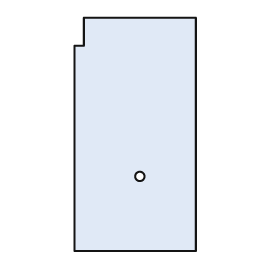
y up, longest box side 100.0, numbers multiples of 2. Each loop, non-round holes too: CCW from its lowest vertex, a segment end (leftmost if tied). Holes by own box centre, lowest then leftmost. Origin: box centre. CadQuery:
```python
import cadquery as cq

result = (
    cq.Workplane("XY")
    .moveTo(-26.0, -50.0)
    .lineTo(26.0, -50.0)
    .lineTo(26.0, 50.0)
    .lineTo(-22.0, 50.0)
    .lineTo(-22.0, 38.0)
    .lineTo(-26.0, 38.0)
    .close()
    .moveTo(2.0, -18.0)
    .circle(2.0)
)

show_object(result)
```